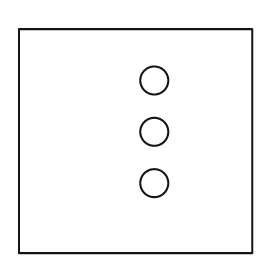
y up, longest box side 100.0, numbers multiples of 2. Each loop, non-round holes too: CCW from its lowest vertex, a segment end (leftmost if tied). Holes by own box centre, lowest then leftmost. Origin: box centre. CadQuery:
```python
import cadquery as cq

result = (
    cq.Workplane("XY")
    .moveTo(-50.0, -48.0)
    .lineTo(50.0, -48.0)
    .lineTo(50.0, 48.0)
    .lineTo(-50.0, 48.0)
    .close()
    .moveTo(8.0, -18.0)
    .circle(6.0)
    .moveTo(8.0, 4.0)
    .circle(6.0)
    .moveTo(8.0, 26.0)
    .circle(6.0)
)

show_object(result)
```